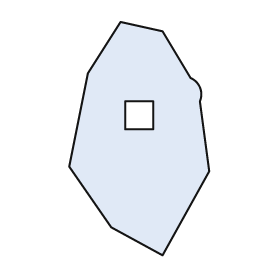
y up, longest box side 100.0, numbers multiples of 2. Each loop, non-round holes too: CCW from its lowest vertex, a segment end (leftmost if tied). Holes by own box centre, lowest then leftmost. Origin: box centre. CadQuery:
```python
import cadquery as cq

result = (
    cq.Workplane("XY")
    .moveTo(10.0, -50.0)
    .lineTo(30.0, -14.0)
    .lineTo(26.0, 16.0)
    .threePointArc((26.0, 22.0), (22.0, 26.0))
    .lineTo(10.0, 46.0)
    .lineTo(-8.0, 50.0)
    .lineTo(-22.0, 28.0)
    .lineTo(-30.0, -12.0)
    .lineTo(-12.0, -38.0)
    .close()
    .moveTo(-6.0, 4.0)
    .lineTo(6.0, 4.0)
    .lineTo(6.0, 16.0)
    .lineTo(-6.0, 16.0)
    .close()
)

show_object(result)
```